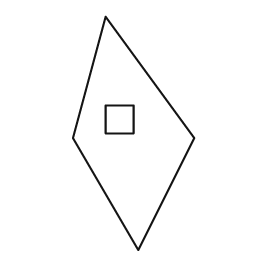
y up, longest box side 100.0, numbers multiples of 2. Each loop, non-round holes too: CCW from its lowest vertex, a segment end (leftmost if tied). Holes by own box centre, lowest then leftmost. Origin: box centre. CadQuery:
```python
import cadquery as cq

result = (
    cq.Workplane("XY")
    .moveTo(2.0, -50.0)
    .lineTo(26.0, -2.0)
    .lineTo(-12.0, 50.0)
    .lineTo(-26.0, -2.0)
    .close()
    .moveTo(-12.0, 0.0)
    .lineTo(0.0, 0.0)
    .lineTo(0.0, 12.0)
    .lineTo(-12.0, 12.0)
    .close()
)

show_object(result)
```